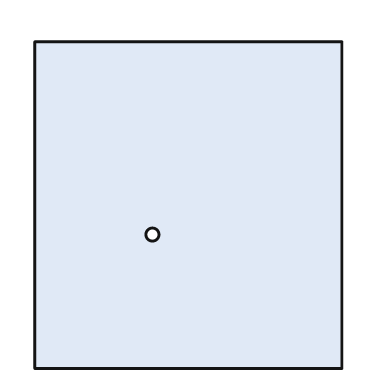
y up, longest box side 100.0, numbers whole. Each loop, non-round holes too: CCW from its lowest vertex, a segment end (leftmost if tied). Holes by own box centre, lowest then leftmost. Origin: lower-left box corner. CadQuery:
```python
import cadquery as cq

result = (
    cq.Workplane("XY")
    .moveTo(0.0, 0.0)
    .lineTo(94.0, 0.0)
    .lineTo(94.0, 100.0)
    .lineTo(0.0, 100.0)
    .close()
    .moveTo(36.0, 41.0)
    .circle(2.0)
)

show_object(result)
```